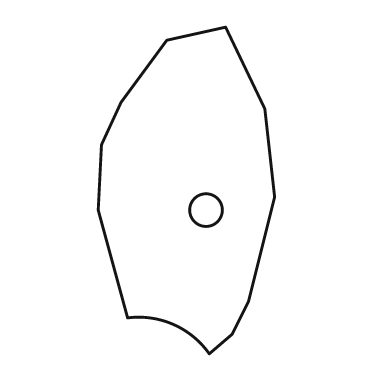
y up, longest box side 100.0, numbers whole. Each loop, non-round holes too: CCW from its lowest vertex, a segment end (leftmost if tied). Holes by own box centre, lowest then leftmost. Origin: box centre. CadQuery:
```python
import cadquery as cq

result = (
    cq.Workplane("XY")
    .moveTo(7.0, -50.0)
    .lineTo(14.0, -44.0)
    .lineTo(19.0, -34.0)
    .lineTo(27.0, -2.0)
    .lineTo(24.0, 25.0)
    .lineTo(12.0, 50.0)
    .lineTo(-6.0, 46.0)
    .lineTo(-20.0, 27.0)
    .lineTo(-26.0, 14.0)
    .lineTo(-27.0, -6.0)
    .lineTo(-18.0, -39.0)
    .threePointArc((-4.0, -41.0), (7.0, -50.0))
    .close()
    .moveTo(6.0, -6.0)
    .circle(5.0)
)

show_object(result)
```